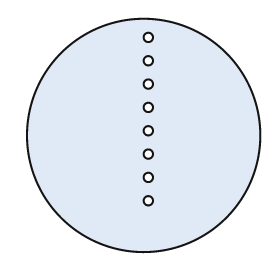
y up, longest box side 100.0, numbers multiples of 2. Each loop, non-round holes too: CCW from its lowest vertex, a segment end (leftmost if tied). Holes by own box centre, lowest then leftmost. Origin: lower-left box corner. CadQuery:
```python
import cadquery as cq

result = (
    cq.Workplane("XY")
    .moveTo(50.0, 50.0)
    .circle(50.0)
    .moveTo(52.0, 22.0)
    .circle(2.0)
    .moveTo(52.0, 32.0)
    .circle(2.0)
    .moveTo(52.0, 42.0)
    .circle(2.0)
    .moveTo(52.0, 52.0)
    .circle(2.0)
    .moveTo(52.0, 62.0)
    .circle(2.0)
    .moveTo(52.0, 72.0)
    .circle(2.0)
    .moveTo(52.0, 82.0)
    .circle(2.0)
    .moveTo(52.0, 92.0)
    .circle(2.0)
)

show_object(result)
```